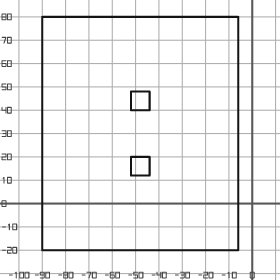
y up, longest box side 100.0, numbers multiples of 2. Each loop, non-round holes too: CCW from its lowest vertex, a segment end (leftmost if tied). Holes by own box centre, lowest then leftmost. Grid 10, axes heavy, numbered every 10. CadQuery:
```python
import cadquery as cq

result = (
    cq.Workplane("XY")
    .moveTo(-90.0, -20.0)
    .lineTo(-6.0, -20.0)
    .lineTo(-6.0, 80.0)
    .lineTo(-90.0, 80.0)
    .close()
    .moveTo(-52.0, 12.0)
    .lineTo(-44.0, 12.0)
    .lineTo(-44.0, 20.0)
    .lineTo(-52.0, 20.0)
    .close()
    .moveTo(-52.0, 40.0)
    .lineTo(-44.0, 40.0)
    .lineTo(-44.0, 48.0)
    .lineTo(-52.0, 48.0)
    .close()
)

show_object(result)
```